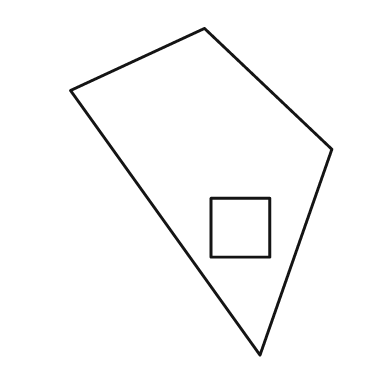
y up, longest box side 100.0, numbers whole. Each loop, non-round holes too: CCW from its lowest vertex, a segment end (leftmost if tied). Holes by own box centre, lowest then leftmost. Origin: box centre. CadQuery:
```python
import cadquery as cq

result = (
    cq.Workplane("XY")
    .moveTo(18.0, -50.0)
    .lineTo(40.0, 13.0)
    .lineTo(1.0, 50.0)
    .lineTo(-40.0, 31.0)
    .close()
    .moveTo(3.0, -20.0)
    .lineTo(21.0, -20.0)
    .lineTo(21.0, -2.0)
    .lineTo(3.0, -2.0)
    .close()
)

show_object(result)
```